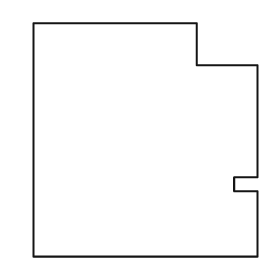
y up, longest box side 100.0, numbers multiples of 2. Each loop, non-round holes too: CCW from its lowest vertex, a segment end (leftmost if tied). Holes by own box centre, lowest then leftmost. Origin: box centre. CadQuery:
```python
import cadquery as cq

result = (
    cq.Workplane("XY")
    .moveTo(-48.0, -50.0)
    .lineTo(48.0, -50.0)
    .lineTo(48.0, -22.0)
    .lineTo(38.0, -22.0)
    .lineTo(38.0, -16.0)
    .lineTo(48.0, -16.0)
    .lineTo(48.0, 32.0)
    .lineTo(22.0, 32.0)
    .lineTo(22.0, 50.0)
    .lineTo(-48.0, 50.0)
    .close()
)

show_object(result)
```